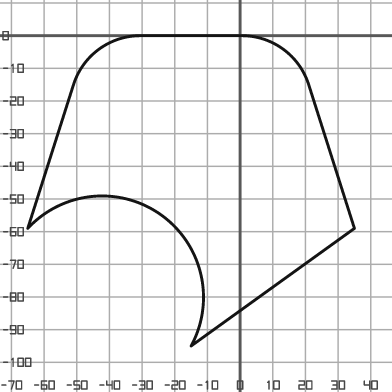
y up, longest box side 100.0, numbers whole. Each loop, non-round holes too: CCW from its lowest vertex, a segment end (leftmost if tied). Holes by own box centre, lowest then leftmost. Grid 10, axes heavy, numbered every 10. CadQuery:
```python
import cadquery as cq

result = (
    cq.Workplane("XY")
    .moveTo(-15.0, -95.0)
    .lineTo(35.0, -59.0)
    .lineTo(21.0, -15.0)
    .threePointArc((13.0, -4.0), (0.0, 0.0))
    .lineTo(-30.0, 0.0)
    .threePointArc((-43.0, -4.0), (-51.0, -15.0))
    .lineTo(-65.0, -59.0)
    .threePointArc((-24.0, -55.0), (-15.0, -95.0))
    .close()
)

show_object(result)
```